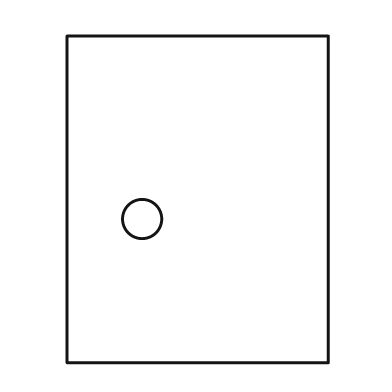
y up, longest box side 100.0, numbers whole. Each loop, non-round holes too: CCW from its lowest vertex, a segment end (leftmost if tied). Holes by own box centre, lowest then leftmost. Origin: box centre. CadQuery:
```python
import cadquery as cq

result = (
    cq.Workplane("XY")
    .moveTo(-40.0, -50.0)
    .lineTo(40.0, -50.0)
    .lineTo(40.0, 50.0)
    .lineTo(-40.0, 50.0)
    .close()
    .moveTo(-17.0, -6.0)
    .circle(6.0)
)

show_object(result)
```